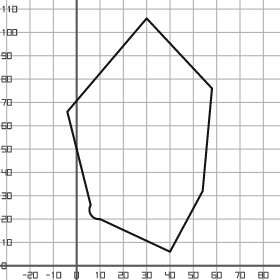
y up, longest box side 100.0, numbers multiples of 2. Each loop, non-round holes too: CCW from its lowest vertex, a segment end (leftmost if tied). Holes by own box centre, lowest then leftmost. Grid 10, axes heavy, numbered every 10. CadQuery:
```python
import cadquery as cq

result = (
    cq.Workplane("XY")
    .moveTo(40.0, 6.0)
    .lineTo(54.0, 32.0)
    .lineTo(58.0, 76.0)
    .lineTo(30.0, 106.0)
    .lineTo(-4.0, 66.0)
    .lineTo(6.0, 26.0)
    .threePointArc((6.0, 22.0), (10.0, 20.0))
    .close()
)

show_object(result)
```